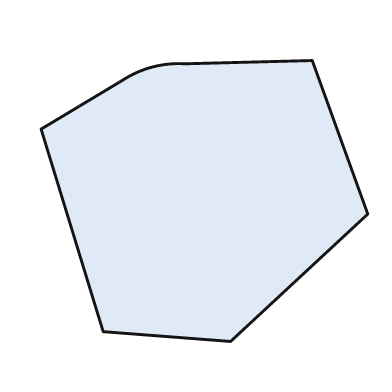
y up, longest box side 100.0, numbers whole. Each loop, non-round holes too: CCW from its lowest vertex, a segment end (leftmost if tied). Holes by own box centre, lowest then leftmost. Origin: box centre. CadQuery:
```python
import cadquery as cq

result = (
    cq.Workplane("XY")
    .moveTo(8.0, -43.0)
    .lineTo(50.0, -4.0)
    .lineTo(33.0, 43.0)
    .lineTo(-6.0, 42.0)
    .threePointArc((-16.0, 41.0), (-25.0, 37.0))
    .lineTo(-50.0, 22.0)
    .lineTo(-31.0, -40.0)
    .close()
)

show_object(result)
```